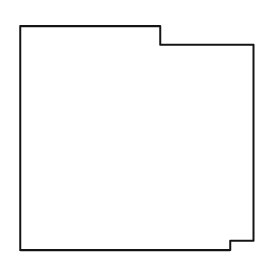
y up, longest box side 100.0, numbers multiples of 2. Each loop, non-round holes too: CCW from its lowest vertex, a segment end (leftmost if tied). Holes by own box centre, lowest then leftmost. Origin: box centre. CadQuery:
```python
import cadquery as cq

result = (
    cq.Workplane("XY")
    .moveTo(-50.0, -48.0)
    .lineTo(40.0, -48.0)
    .lineTo(40.0, -44.0)
    .lineTo(50.0, -44.0)
    .lineTo(50.0, 40.0)
    .lineTo(10.0, 40.0)
    .lineTo(10.0, 48.0)
    .lineTo(-50.0, 48.0)
    .close()
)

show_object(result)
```